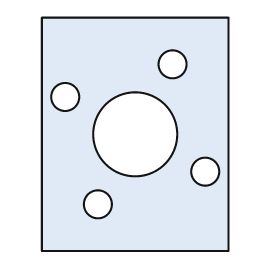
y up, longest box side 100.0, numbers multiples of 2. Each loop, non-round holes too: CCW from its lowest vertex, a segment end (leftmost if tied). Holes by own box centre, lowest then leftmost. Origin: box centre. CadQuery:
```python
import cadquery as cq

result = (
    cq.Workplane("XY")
    .moveTo(-40.0, -50.0)
    .lineTo(40.0, -50.0)
    .lineTo(40.0, 50.0)
    .lineTo(-40.0, 50.0)
    .close()
    .moveTo(-16.0, -30.0)
    .circle(6.0)
    .moveTo(30.0, -16.0)
    .circle(6.0)
    .moveTo(0.0, 0.0)
    .circle(18.0)
    .moveTo(-30.0, 16.0)
    .circle(6.0)
    .moveTo(16.0, 30.0)
    .circle(6.0)
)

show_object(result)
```